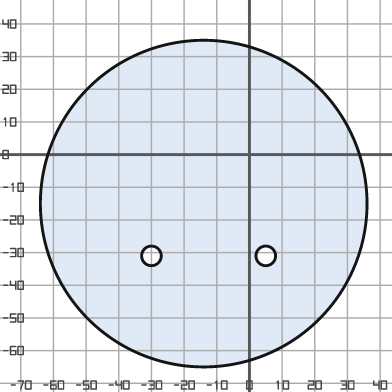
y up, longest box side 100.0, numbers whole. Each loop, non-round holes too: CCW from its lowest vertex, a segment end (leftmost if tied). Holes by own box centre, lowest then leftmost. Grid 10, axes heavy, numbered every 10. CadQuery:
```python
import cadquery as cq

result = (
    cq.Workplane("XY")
    .moveTo(-14.0, -15.0)
    .circle(50.0)
    .moveTo(-30.0, -31.0)
    .circle(3.0)
    .moveTo(5.0, -31.0)
    .circle(3.0)
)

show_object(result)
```